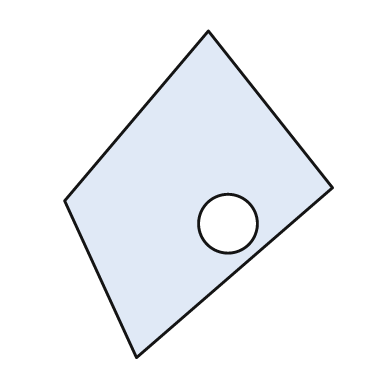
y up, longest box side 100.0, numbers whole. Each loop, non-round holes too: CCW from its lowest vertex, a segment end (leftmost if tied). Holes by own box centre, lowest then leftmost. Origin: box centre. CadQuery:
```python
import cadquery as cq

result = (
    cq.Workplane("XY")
    .moveTo(-19.0, -50.0)
    .lineTo(41.0, 2.0)
    .lineTo(3.0, 50.0)
    .lineTo(-41.0, -2.0)
    .close()
    .moveTo(9.0, -9.0)
    .circle(9.0)
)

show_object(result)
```